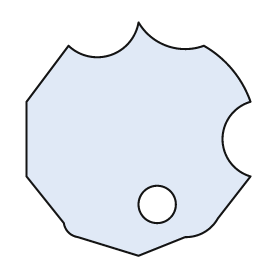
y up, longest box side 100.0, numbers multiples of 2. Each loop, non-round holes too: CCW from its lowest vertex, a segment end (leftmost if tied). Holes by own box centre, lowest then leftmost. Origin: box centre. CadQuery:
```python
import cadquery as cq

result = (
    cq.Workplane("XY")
    .moveTo(0.0, -50.0)
    .lineTo(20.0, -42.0)
    .threePointArc((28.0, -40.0), (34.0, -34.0))
    .lineTo(48.0, -16.0)
    .threePointArc((36.0, 0.0), (48.0, 16.0))
    .threePointArc((40.0, 30.0), (28.0, 40.0))
    .threePointArc((12.0, 40.0), (0.0, 50.0))
    .threePointArc((-12.0, 36.0), (-30.0, 40.0))
    .lineTo(-48.0, 16.0)
    .lineTo(-48.0, -16.0)
    .lineTo(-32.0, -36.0)
    .threePointArc((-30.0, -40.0), (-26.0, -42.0))
    .close()
    .moveTo(8.0, -28.0)
    .circle(8.0)
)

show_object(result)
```